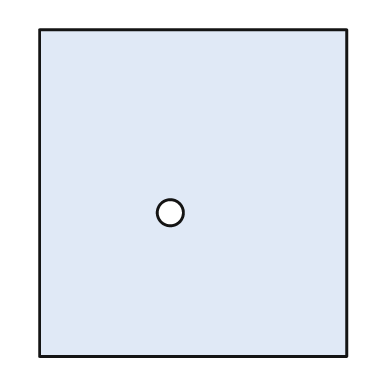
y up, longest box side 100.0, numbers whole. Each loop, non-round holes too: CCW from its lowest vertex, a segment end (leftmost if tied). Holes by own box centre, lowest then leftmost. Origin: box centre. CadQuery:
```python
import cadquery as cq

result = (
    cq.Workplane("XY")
    .moveTo(-47.0, -50.0)
    .lineTo(47.0, -50.0)
    .lineTo(47.0, 50.0)
    .lineTo(-47.0, 50.0)
    .close()
    .moveTo(-7.0, -6.0)
    .circle(4.0)
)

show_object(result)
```